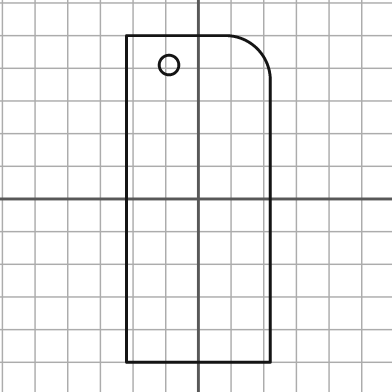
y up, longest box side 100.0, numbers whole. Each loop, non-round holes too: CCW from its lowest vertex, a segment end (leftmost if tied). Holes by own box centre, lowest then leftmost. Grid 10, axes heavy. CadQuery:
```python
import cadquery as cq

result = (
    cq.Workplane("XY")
    .moveTo(-22.0, -50.0)
    .lineTo(22.0, -50.0)
    .lineTo(22.0, 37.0)
    .threePointArc((18.0, 46.0), (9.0, 50.0))
    .lineTo(-22.0, 50.0)
    .close()
    .moveTo(-9.0, 41.0)
    .circle(3.0)
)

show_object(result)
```